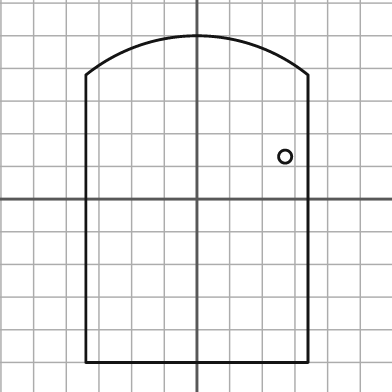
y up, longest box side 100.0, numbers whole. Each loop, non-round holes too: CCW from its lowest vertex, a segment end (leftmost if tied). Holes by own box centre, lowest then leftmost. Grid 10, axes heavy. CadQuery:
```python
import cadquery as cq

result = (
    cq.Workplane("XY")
    .moveTo(-34.0, -50.0)
    .lineTo(34.0, -50.0)
    .lineTo(34.0, 38.0)
    .threePointArc((0.0, 50.0), (-34.0, 38.0))
    .close()
    .moveTo(27.0, 13.0)
    .circle(2.0)
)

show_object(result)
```